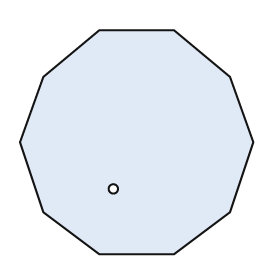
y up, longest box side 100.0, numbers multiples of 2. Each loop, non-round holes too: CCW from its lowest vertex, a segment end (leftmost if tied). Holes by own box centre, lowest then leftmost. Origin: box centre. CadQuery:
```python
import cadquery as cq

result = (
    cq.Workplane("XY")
    .moveTo(-16.0, -48.0)
    .lineTo(16.0, -48.0)
    .lineTo(40.0, -30.0)
    .lineTo(50.0, 0.0)
    .lineTo(40.0, 28.0)
    .lineTo(16.0, 48.0)
    .lineTo(-16.0, 48.0)
    .lineTo(-40.0, 28.0)
    .lineTo(-50.0, 0.0)
    .lineTo(-40.0, -30.0)
    .close()
    .moveTo(-10.0, -20.0)
    .circle(2.0)
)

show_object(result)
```